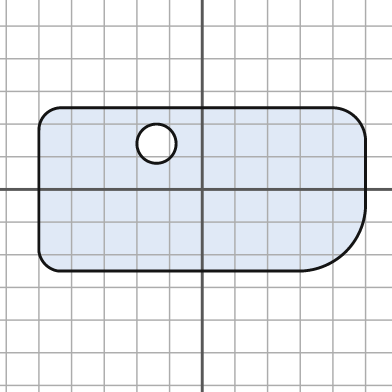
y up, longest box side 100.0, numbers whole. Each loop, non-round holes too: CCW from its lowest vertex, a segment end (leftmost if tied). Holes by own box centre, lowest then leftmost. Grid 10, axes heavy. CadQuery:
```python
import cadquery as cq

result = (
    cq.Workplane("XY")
    .moveTo(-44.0, -25.0)
    .lineTo(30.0, -25.0)
    .threePointArc((44.0, -19.0), (50.0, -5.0))
    .lineTo(50.0, 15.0)
    .threePointArc((47.0, 22.0), (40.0, 25.0))
    .lineTo(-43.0, 25.0)
    .threePointArc((-48.0, 23.0), (-50.0, 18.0))
    .lineTo(-50.0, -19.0)
    .threePointArc((-48.0, -23.0), (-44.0, -25.0))
    .close()
    .moveTo(-14.0, 14.0)
    .circle(6.0)
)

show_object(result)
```